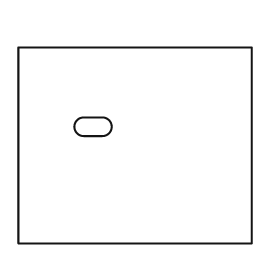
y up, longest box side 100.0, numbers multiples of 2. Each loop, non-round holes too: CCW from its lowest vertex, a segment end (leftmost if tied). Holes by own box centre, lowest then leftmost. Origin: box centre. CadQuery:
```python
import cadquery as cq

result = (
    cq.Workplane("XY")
    .moveTo(-50.0, -42.0)
    .lineTo(50.0, -42.0)
    .lineTo(50.0, 42.0)
    .lineTo(-50.0, 42.0)
    .close()
    .moveTo(-22.0, 4.0)
    .lineTo(-14.0, 4.0)
    .threePointArc((-10.0, 8.0), (-14.0, 12.0))
    .lineTo(-22.0, 12.0)
    .threePointArc((-26.0, 8.0), (-22.0, 4.0))
    .close()
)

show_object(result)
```